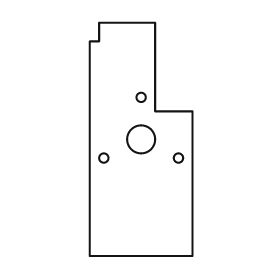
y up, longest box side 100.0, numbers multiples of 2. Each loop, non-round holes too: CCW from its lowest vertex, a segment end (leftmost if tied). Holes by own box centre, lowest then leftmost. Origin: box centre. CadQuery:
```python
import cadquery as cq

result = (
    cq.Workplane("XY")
    .moveTo(-22.0, -50.0)
    .lineTo(22.0, -50.0)
    .lineTo(22.0, 12.0)
    .lineTo(6.0, 12.0)
    .lineTo(6.0, 50.0)
    .lineTo(-18.0, 50.0)
    .lineTo(-18.0, 42.0)
    .lineTo(-22.0, 42.0)
    .close()
    .moveTo(-16.0, -8.0)
    .circle(2.0)
    .moveTo(16.0, -8.0)
    .circle(2.0)
    .moveTo(0.0, 0.0)
    .circle(6.0)
    .moveTo(0.0, 18.0)
    .circle(2.0)
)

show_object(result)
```